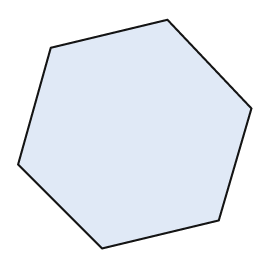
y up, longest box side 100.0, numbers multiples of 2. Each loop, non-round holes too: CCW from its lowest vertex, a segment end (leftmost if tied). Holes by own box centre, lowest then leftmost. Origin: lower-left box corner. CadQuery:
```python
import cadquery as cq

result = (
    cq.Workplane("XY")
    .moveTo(36.0, 0.0)
    .lineTo(86.0, 12.0)
    .lineTo(100.0, 60.0)
    .lineTo(64.0, 98.0)
    .lineTo(14.0, 86.0)
    .lineTo(0.0, 36.0)
    .close()
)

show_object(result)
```